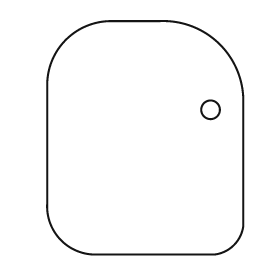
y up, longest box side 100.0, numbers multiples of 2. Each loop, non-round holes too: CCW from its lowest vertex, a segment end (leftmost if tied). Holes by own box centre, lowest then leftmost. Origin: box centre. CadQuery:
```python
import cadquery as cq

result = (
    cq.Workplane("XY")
    .moveTo(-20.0, -50.0)
    .lineTo(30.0, -50.0)
    .threePointArc((38.0, -46.0), (42.0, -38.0))
    .lineTo(42.0, 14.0)
    .threePointArc((32.0, 40.0), (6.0, 50.0))
    .lineTo(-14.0, 50.0)
    .threePointArc((-34.0, 42.0), (-42.0, 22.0))
    .lineTo(-42.0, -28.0)
    .threePointArc((-36.0, -44.0), (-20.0, -50.0))
    .close()
    .moveTo(28.0, 12.0)
    .circle(4.0)
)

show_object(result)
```